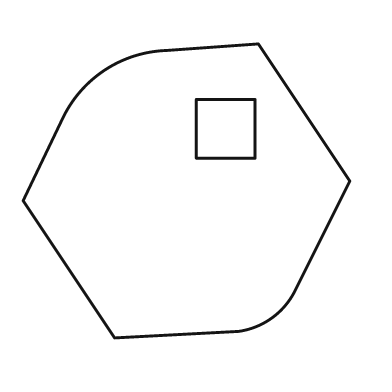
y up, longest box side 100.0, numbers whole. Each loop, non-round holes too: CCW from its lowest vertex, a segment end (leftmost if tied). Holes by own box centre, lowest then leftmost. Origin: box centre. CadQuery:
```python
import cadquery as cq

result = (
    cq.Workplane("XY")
    .moveTo(-22.0, -45.0)
    .lineTo(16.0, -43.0)
    .threePointArc((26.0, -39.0), (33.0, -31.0))
    .lineTo(50.0, 3.0)
    .lineTo(22.0, 45.0)
    .lineTo(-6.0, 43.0)
    .threePointArc((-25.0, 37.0), (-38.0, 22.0))
    .lineTo(-50.0, -3.0)
    .close()
    .moveTo(3.0, 10.0)
    .lineTo(21.0, 10.0)
    .lineTo(21.0, 28.0)
    .lineTo(3.0, 28.0)
    .close()
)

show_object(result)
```